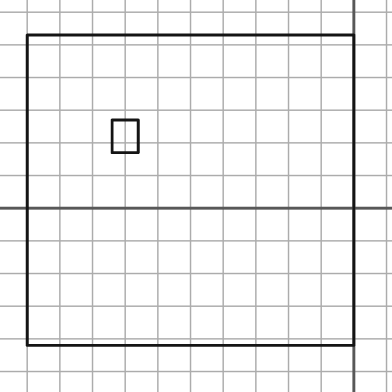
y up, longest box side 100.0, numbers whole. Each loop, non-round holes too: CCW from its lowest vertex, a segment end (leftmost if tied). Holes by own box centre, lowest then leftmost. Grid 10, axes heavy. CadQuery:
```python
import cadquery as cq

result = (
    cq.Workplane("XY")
    .moveTo(-100.0, -42.0)
    .lineTo(0.0, -42.0)
    .lineTo(0.0, 53.0)
    .lineTo(-100.0, 53.0)
    .close()
    .moveTo(-74.0, 17.0)
    .lineTo(-66.0, 17.0)
    .lineTo(-66.0, 27.0)
    .lineTo(-74.0, 27.0)
    .close()
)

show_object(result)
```